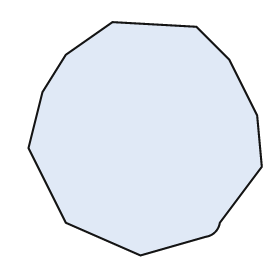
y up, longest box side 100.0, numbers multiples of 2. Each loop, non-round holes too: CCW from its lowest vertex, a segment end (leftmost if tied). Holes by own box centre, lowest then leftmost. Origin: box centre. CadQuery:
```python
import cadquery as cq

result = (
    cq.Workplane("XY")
    .moveTo(-2.0, -50.0)
    .lineTo(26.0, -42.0)
    .threePointArc((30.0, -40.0), (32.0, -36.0))
    .lineTo(50.0, -12.0)
    .lineTo(48.0, 10.0)
    .lineTo(36.0, 34.0)
    .lineTo(22.0, 48.0)
    .lineTo(-14.0, 50.0)
    .lineTo(-34.0, 36.0)
    .lineTo(-44.0, 20.0)
    .lineTo(-50.0, -4.0)
    .lineTo(-34.0, -36.0)
    .close()
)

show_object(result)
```